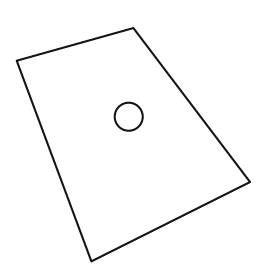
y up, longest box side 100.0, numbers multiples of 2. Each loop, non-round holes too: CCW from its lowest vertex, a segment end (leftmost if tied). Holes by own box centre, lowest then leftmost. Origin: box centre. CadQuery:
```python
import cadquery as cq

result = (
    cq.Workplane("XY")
    .moveTo(-18.0, -50.0)
    .lineTo(50.0, -16.0)
    .lineTo(0.0, 50.0)
    .lineTo(-50.0, 36.0)
    .close()
    .moveTo(-2.0, 12.0)
    .circle(6.0)
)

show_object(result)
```